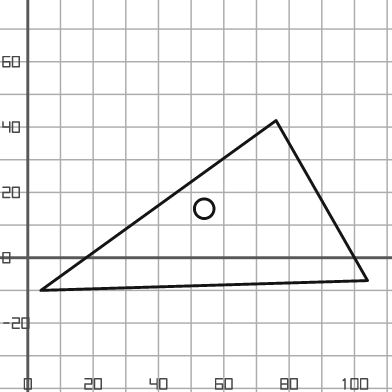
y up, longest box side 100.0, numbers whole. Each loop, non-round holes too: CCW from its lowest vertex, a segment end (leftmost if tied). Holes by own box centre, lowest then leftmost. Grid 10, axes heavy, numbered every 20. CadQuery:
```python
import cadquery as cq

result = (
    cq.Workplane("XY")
    .moveTo(4.0, -10.0)
    .lineTo(104.0, -7.0)
    .lineTo(76.0, 42.0)
    .close()
    .moveTo(54.0, 15.0)
    .circle(3.0)
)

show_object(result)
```